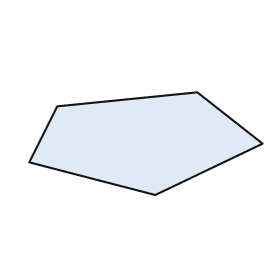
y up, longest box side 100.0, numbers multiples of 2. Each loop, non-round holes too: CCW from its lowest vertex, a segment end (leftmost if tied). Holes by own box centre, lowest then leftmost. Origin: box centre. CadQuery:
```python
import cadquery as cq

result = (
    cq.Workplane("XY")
    .moveTo(4.0, -22.0)
    .lineTo(50.0, 0.0)
    .lineTo(22.0, 22.0)
    .lineTo(-38.0, 16.0)
    .lineTo(-50.0, -8.0)
    .close()
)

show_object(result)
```